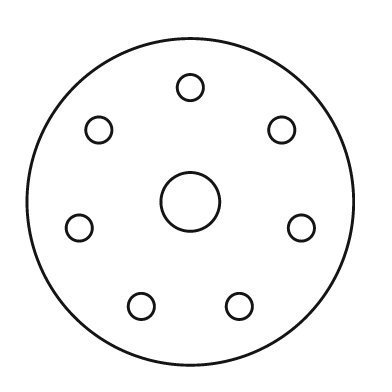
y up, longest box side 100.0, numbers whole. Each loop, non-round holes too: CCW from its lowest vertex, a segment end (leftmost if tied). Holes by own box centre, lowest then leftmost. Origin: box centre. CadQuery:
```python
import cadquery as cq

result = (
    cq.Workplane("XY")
    .moveTo(0.0, 0.0)
    .circle(50.0)
    .moveTo(-15.0, -32.0)
    .circle(4.0)
    .moveTo(15.0, -32.0)
    .circle(4.0)
    .moveTo(-34.0, -8.0)
    .circle(4.0)
    .moveTo(34.0, -8.0)
    .circle(4.0)
    .moveTo(0.0, 0.0)
    .circle(9.0)
    .moveTo(-28.0, 22.0)
    .circle(4.0)
    .moveTo(28.0, 22.0)
    .circle(4.0)
    .moveTo(0.0, 35.0)
    .circle(4.0)
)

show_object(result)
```